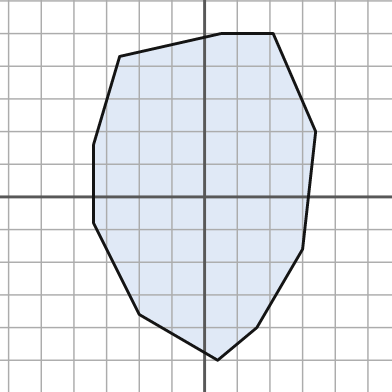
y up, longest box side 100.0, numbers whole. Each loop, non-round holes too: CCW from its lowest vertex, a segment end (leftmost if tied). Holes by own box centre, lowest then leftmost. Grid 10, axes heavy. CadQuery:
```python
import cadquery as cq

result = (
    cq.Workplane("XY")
    .moveTo(4.0, -50.0)
    .lineTo(16.0, -40.0)
    .lineTo(30.0, -16.0)
    .lineTo(34.0, 20.0)
    .lineTo(21.0, 50.0)
    .lineTo(5.0, 50.0)
    .lineTo(-26.0, 43.0)
    .lineTo(-34.0, 16.0)
    .lineTo(-34.0, -8.0)
    .lineTo(-20.0, -36.0)
    .close()
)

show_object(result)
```